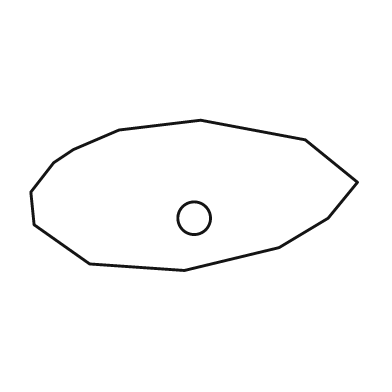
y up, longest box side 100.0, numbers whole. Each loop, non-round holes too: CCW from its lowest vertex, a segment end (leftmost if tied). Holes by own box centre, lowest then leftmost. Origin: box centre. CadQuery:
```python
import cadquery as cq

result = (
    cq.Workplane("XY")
    .moveTo(-3.0, -23.0)
    .lineTo(26.0, -16.0)
    .lineTo(41.0, -7.0)
    .lineTo(50.0, 4.0)
    .lineTo(34.0, 17.0)
    .lineTo(2.0, 23.0)
    .lineTo(-23.0, 20.0)
    .lineTo(-37.0, 14.0)
    .lineTo(-43.0, 10.0)
    .lineTo(-50.0, 1.0)
    .lineTo(-49.0, -9.0)
    .lineTo(-32.0, -21.0)
    .close()
    .moveTo(0.0, -7.0)
    .circle(5.0)
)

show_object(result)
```